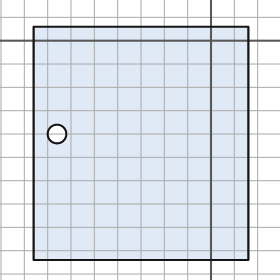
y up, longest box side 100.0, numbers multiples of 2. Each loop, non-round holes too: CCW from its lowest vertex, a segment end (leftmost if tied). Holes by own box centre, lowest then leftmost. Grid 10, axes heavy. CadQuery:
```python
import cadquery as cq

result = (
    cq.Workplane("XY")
    .moveTo(-76.0, -94.0)
    .lineTo(16.0, -94.0)
    .lineTo(16.0, 6.0)
    .lineTo(-76.0, 6.0)
    .close()
    .moveTo(-66.0, -40.0)
    .circle(4.0)
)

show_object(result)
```